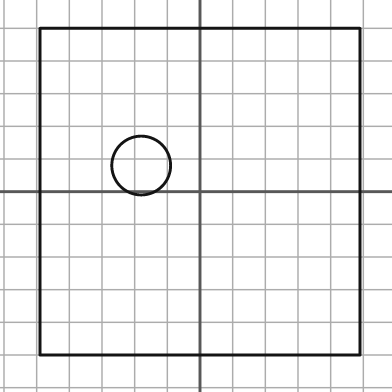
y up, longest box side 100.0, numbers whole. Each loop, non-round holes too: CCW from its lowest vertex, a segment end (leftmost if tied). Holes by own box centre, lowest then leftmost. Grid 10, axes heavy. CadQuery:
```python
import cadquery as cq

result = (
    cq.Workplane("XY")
    .moveTo(-49.0, -50.0)
    .lineTo(49.0, -50.0)
    .lineTo(49.0, 50.0)
    .lineTo(-49.0, 50.0)
    .close()
    .moveTo(-18.0, 8.0)
    .circle(9.0)
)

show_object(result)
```